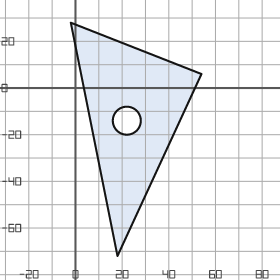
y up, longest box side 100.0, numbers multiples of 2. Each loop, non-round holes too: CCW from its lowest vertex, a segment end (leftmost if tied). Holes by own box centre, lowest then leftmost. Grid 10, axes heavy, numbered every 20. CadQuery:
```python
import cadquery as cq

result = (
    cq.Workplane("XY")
    .moveTo(18.0, -72.0)
    .lineTo(54.0, 6.0)
    .lineTo(-2.0, 28.0)
    .close()
    .moveTo(22.0, -14.0)
    .circle(6.0)
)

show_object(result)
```